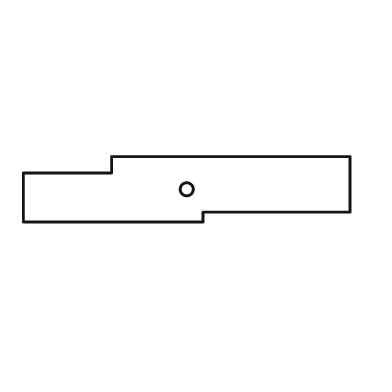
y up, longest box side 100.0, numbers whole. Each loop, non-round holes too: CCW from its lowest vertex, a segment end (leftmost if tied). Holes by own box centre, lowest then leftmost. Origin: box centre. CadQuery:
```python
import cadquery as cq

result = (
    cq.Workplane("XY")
    .moveTo(-50.0, -10.0)
    .lineTo(5.0, -10.0)
    .lineTo(5.0, -7.0)
    .lineTo(50.0, -7.0)
    .lineTo(50.0, 10.0)
    .lineTo(-23.0, 10.0)
    .lineTo(-23.0, 5.0)
    .lineTo(-50.0, 5.0)
    .close()
    .moveTo(0.0, 0.0)
    .circle(2.0)
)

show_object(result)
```